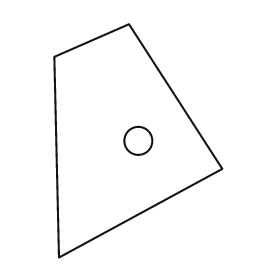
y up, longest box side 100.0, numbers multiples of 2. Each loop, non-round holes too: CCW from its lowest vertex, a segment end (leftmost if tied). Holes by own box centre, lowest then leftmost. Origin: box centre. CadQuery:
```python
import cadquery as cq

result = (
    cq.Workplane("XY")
    .moveTo(-34.0, -50.0)
    .lineTo(36.0, -12.0)
    .lineTo(-4.0, 50.0)
    .lineTo(-36.0, 36.0)
    .close()
    .moveTo(0.0, 0.0)
    .circle(6.0)
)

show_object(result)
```